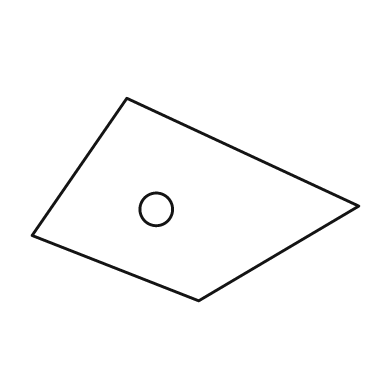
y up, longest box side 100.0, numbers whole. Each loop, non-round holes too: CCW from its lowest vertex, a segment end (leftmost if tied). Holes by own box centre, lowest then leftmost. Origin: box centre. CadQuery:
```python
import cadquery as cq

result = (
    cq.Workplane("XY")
    .moveTo(1.0, -31.0)
    .lineTo(50.0, -2.0)
    .lineTo(-21.0, 31.0)
    .lineTo(-50.0, -11.0)
    .close()
    .moveTo(-12.0, -3.0)
    .circle(5.0)
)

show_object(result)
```